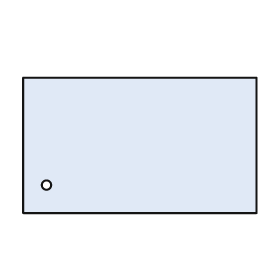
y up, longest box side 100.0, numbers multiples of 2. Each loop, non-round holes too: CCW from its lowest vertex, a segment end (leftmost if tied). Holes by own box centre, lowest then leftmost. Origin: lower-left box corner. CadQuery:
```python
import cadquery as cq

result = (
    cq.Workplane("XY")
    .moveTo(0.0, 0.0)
    .lineTo(100.0, 0.0)
    .lineTo(100.0, 58.0)
    .lineTo(0.0, 58.0)
    .close()
    .moveTo(10.0, 12.0)
    .circle(2.0)
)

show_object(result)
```